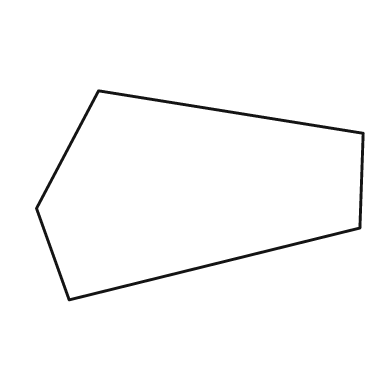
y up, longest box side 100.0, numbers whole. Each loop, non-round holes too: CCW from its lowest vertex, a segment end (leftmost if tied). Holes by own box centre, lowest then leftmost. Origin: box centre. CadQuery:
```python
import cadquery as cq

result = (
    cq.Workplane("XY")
    .moveTo(-40.0, -32.0)
    .lineTo(49.0, -10.0)
    .lineTo(50.0, 19.0)
    .lineTo(-31.0, 32.0)
    .lineTo(-50.0, -4.0)
    .close()
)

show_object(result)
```